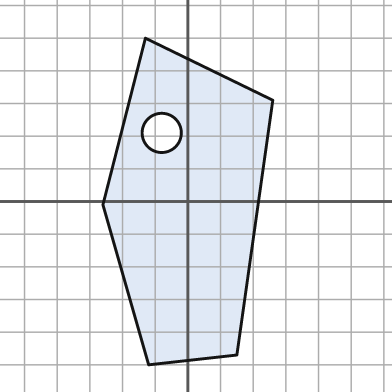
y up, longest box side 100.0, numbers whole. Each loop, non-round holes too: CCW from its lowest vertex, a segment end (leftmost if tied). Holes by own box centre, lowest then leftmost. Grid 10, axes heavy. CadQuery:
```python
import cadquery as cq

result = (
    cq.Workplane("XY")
    .moveTo(-12.0, -50.0)
    .lineTo(15.0, -47.0)
    .lineTo(26.0, 31.0)
    .lineTo(-13.0, 50.0)
    .lineTo(-26.0, -1.0)
    .close()
    .moveTo(-8.0, 21.0)
    .circle(6.0)
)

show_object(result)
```